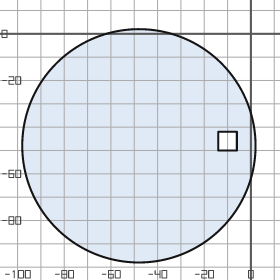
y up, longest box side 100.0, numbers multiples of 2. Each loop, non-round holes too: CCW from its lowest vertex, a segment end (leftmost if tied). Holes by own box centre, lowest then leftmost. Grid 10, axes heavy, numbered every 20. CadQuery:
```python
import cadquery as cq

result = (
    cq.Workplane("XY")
    .moveTo(-48.0, -48.0)
    .circle(50.0)
    .moveTo(-14.0, -50.0)
    .lineTo(-6.0, -50.0)
    .lineTo(-6.0, -42.0)
    .lineTo(-14.0, -42.0)
    .close()
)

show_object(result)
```